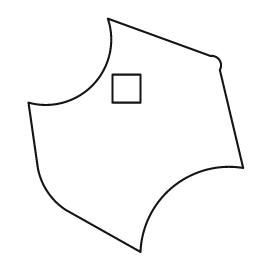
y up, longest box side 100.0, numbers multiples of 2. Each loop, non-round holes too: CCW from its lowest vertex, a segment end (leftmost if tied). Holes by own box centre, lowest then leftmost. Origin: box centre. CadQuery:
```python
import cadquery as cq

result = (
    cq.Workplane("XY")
    .moveTo(2.0, -50.0)
    .threePointArc((16.0, -22.0), (46.0, -14.0))
    .lineTo(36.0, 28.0)
    .threePointArc((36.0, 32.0), (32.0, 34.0))
    .lineTo(-12.0, 50.0)
    .threePointArc((-18.0, 22.0), (-46.0, 14.0))
    .lineTo(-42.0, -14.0)
    .threePointArc((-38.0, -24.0), (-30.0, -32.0))
    .close()
    .moveTo(-10.0, 14.0)
    .lineTo(2.0, 14.0)
    .lineTo(2.0, 26.0)
    .lineTo(-10.0, 26.0)
    .close()
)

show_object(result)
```